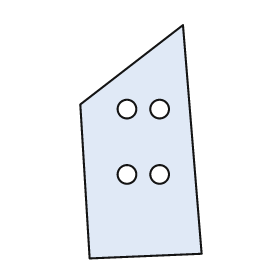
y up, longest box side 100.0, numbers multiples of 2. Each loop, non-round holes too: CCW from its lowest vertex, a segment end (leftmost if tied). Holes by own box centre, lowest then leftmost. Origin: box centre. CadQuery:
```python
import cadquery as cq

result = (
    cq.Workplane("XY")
    .moveTo(-22.0, -50.0)
    .lineTo(26.0, -48.0)
    .lineTo(18.0, 50.0)
    .lineTo(-26.0, 16.0)
    .close()
    .moveTo(-6.0, -14.0)
    .circle(4.0)
    .moveTo(8.0, -14.0)
    .circle(4.0)
    .moveTo(-6.0, 14.0)
    .circle(4.0)
    .moveTo(8.0, 14.0)
    .circle(4.0)
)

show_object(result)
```